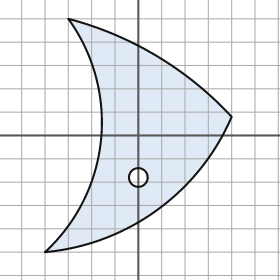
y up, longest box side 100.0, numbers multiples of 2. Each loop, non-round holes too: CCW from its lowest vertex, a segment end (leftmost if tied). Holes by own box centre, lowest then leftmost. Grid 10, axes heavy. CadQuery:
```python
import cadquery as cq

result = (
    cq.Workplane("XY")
    .moveTo(-40.0, -50.0)
    .threePointArc((8.0, -32.0), (40.0, 8.0))
    .threePointArc((8.0, 34.0), (-30.0, 50.0))
    .threePointArc((-16.0, -2.0), (-40.0, -50.0))
    .close()
    .moveTo(0.0, -18.0)
    .circle(4.0)
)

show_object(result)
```